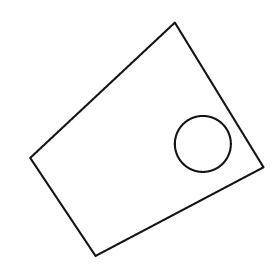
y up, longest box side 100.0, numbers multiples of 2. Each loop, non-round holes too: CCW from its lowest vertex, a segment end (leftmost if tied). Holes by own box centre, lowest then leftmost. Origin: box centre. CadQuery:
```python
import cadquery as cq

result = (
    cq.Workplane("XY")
    .moveTo(-22.0, -50.0)
    .lineTo(50.0, -12.0)
    .lineTo(12.0, 50.0)
    .lineTo(-50.0, -8.0)
    .close()
    .moveTo(24.0, -2.0)
    .circle(12.0)
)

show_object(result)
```